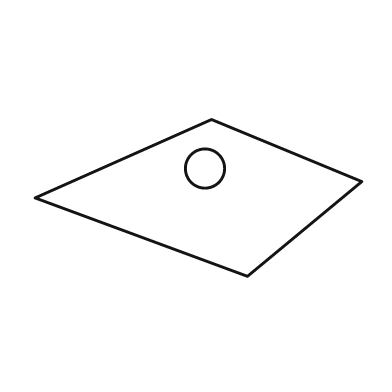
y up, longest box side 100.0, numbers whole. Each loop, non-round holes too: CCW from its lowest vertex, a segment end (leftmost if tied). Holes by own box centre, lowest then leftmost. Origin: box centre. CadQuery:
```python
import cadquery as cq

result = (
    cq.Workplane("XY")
    .moveTo(15.0, -24.0)
    .lineTo(50.0, 5.0)
    .lineTo(4.0, 24.0)
    .lineTo(-50.0, 0.0)
    .close()
    .moveTo(2.0, 9.0)
    .circle(6.0)
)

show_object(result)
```